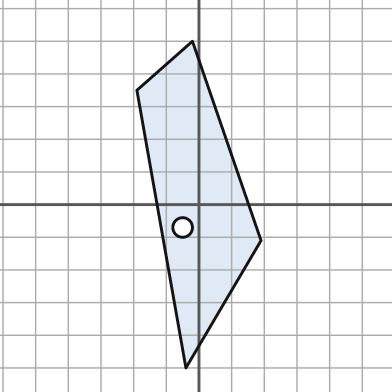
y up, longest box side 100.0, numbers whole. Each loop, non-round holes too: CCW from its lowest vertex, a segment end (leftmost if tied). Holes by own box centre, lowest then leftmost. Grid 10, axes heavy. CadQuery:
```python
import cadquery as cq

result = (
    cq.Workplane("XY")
    .moveTo(-4.0, -50.0)
    .lineTo(19.0, -11.0)
    .lineTo(-2.0, 50.0)
    .lineTo(-19.0, 35.0)
    .close()
    .moveTo(-5.0, -7.0)
    .circle(3.0)
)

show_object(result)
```